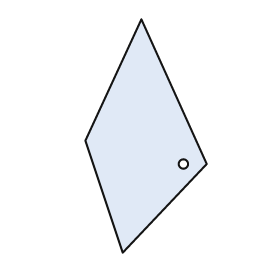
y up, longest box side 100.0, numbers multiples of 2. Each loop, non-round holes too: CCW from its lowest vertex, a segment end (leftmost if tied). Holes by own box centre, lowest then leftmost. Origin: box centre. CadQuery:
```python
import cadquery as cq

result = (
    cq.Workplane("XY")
    .moveTo(-10.0, -50.0)
    .lineTo(26.0, -12.0)
    .lineTo(-2.0, 50.0)
    .lineTo(-26.0, -2.0)
    .close()
    .moveTo(16.0, -12.0)
    .circle(2.0)
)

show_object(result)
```